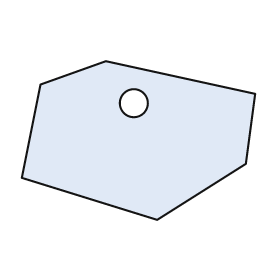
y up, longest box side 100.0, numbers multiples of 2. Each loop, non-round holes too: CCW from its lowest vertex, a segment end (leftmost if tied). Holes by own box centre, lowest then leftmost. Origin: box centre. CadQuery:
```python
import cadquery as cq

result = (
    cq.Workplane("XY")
    .moveTo(8.0, -34.0)
    .lineTo(46.0, -10.0)
    .lineTo(50.0, 20.0)
    .lineTo(-14.0, 34.0)
    .lineTo(-42.0, 24.0)
    .lineTo(-50.0, -16.0)
    .close()
    .moveTo(-2.0, 16.0)
    .circle(6.0)
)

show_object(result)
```